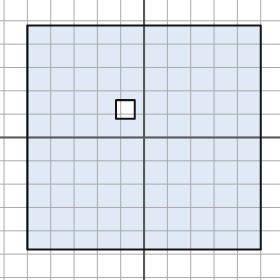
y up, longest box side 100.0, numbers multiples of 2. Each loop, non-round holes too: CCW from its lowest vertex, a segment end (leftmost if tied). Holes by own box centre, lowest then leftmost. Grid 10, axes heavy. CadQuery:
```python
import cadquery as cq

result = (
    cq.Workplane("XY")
    .moveTo(-50.0, -48.0)
    .lineTo(50.0, -48.0)
    .lineTo(50.0, 48.0)
    .lineTo(-50.0, 48.0)
    .close()
    .moveTo(-12.0, 8.0)
    .lineTo(-4.0, 8.0)
    .lineTo(-4.0, 16.0)
    .lineTo(-12.0, 16.0)
    .close()
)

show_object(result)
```